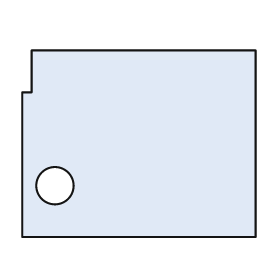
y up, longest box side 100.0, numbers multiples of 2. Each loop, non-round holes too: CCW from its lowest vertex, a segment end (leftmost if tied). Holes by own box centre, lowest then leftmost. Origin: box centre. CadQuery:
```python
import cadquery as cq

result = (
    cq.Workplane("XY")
    .moveTo(-50.0, -40.0)
    .lineTo(50.0, -40.0)
    .lineTo(50.0, 40.0)
    .lineTo(-46.0, 40.0)
    .lineTo(-46.0, 22.0)
    .lineTo(-50.0, 22.0)
    .close()
    .moveTo(-36.0, -18.0)
    .circle(8.0)
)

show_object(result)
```